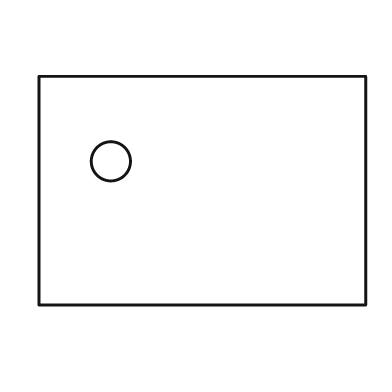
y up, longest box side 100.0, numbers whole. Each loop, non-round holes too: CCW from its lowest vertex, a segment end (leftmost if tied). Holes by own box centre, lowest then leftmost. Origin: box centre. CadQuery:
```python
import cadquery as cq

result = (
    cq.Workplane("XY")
    .moveTo(-50.0, -35.0)
    .lineTo(50.0, -35.0)
    .lineTo(50.0, 35.0)
    .lineTo(-50.0, 35.0)
    .close()
    .moveTo(-28.0, 9.0)
    .circle(6.0)
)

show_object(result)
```